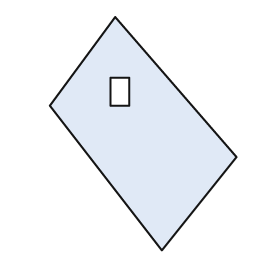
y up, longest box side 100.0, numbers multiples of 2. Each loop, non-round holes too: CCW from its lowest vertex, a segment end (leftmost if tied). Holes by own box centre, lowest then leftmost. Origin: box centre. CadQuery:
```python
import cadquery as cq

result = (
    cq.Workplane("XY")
    .moveTo(8.0, -50.0)
    .lineTo(40.0, -10.0)
    .lineTo(-12.0, 50.0)
    .lineTo(-40.0, 12.0)
    .close()
    .moveTo(-14.0, 12.0)
    .lineTo(-6.0, 12.0)
    .lineTo(-6.0, 24.0)
    .lineTo(-14.0, 24.0)
    .close()
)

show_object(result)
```